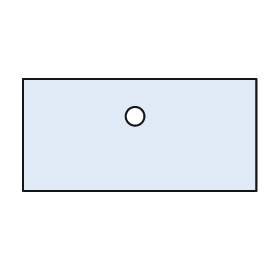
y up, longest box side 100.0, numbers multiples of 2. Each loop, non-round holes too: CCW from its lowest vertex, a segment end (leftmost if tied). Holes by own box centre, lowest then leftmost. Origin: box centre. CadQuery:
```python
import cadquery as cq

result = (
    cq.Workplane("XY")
    .moveTo(-50.0, -24.0)
    .lineTo(50.0, -24.0)
    .lineTo(50.0, 24.0)
    .lineTo(-50.0, 24.0)
    .close()
    .moveTo(-2.0, 8.0)
    .circle(4.0)
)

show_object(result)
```